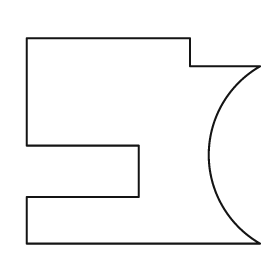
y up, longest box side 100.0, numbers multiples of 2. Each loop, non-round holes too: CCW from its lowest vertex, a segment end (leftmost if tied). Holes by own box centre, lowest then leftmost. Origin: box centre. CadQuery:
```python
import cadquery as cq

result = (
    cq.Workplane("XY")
    .moveTo(-50.0, -44.0)
    .lineTo(50.0, -44.0)
    .threePointArc((28.0, -6.0), (50.0, 32.0))
    .lineTo(20.0, 32.0)
    .lineTo(20.0, 44.0)
    .lineTo(-50.0, 44.0)
    .lineTo(-50.0, -2.0)
    .lineTo(-2.0, -2.0)
    .lineTo(-2.0, -24.0)
    .lineTo(-50.0, -24.0)
    .close()
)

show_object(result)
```